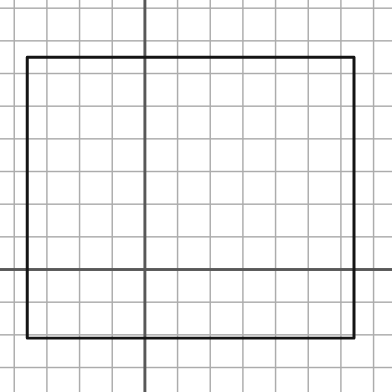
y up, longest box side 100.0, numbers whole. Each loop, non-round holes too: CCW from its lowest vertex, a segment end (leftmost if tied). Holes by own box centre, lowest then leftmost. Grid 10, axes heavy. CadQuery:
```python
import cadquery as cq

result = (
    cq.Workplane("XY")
    .moveTo(-36.0, -21.0)
    .lineTo(64.0, -21.0)
    .lineTo(64.0, 65.0)
    .lineTo(-36.0, 65.0)
    .close()
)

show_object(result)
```